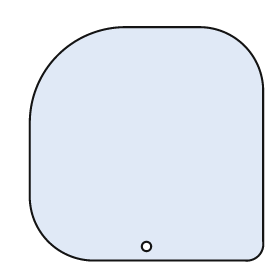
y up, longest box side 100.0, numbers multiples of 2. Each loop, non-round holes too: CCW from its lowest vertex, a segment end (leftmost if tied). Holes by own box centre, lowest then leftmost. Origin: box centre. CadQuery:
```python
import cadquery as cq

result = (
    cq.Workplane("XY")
    .moveTo(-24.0, -50.0)
    .lineTo(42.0, -50.0)
    .threePointArc((48.0, -48.0), (50.0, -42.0))
    .lineTo(50.0, 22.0)
    .threePointArc((42.0, 42.0), (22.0, 50.0))
    .lineTo(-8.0, 50.0)
    .threePointArc((-38.0, 38.0), (-50.0, 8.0))
    .lineTo(-50.0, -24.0)
    .threePointArc((-42.0, -42.0), (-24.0, -50.0))
    .close()
    .moveTo(0.0, -44.0)
    .circle(2.0)
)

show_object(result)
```